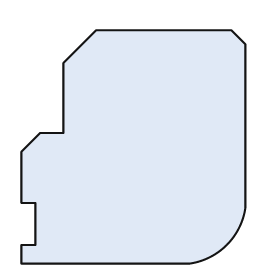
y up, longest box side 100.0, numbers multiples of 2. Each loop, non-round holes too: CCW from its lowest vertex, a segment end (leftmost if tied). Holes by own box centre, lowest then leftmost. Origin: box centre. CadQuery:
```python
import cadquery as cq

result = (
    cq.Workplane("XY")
    .moveTo(-48.0, -50.0)
    .lineTo(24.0, -50.0)
    .threePointArc((40.0, -42.0), (48.0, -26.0))
    .lineTo(48.0, 44.0)
    .lineTo(42.0, 50.0)
    .lineTo(-16.0, 50.0)
    .lineTo(-30.0, 36.0)
    .lineTo(-30.0, 6.0)
    .lineTo(-40.0, 6.0)
    .lineTo(-48.0, -2.0)
    .lineTo(-48.0, -24.0)
    .lineTo(-42.0, -24.0)
    .lineTo(-42.0, -42.0)
    .lineTo(-48.0, -42.0)
    .close()
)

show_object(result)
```